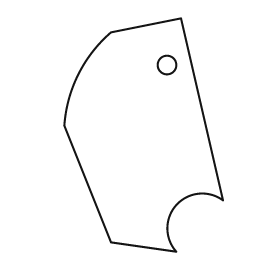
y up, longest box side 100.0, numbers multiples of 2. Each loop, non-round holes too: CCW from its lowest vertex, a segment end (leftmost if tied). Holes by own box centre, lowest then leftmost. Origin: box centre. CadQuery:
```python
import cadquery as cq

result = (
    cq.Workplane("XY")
    .moveTo(14.0, -50.0)
    .threePointArc((14.0, -30.0), (34.0, -28.0))
    .lineTo(16.0, 50.0)
    .lineTo(-14.0, 44.0)
    .threePointArc((-28.0, 26.0), (-34.0, 4.0))
    .lineTo(-14.0, -46.0)
    .close()
    .moveTo(10.0, 30.0)
    .circle(4.0)
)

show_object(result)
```